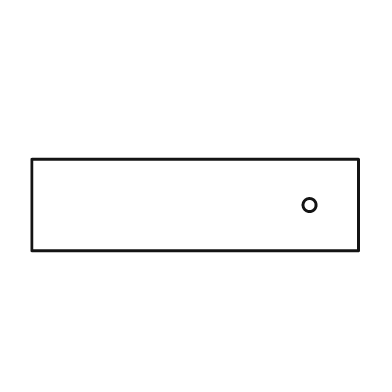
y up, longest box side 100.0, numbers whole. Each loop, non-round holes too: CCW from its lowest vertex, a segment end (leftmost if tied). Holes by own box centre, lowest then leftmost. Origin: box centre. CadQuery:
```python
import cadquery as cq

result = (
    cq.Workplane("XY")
    .moveTo(-50.0, -14.0)
    .lineTo(50.0, -14.0)
    .lineTo(50.0, 14.0)
    .lineTo(-50.0, 14.0)
    .close()
    .moveTo(35.0, 0.0)
    .circle(2.0)
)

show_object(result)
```